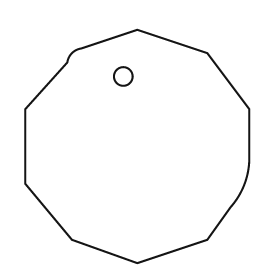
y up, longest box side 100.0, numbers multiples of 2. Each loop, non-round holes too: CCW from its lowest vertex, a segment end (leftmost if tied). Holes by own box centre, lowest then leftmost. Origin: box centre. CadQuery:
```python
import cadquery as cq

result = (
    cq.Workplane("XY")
    .moveTo(0.0, -50.0)
    .lineTo(30.0, -40.0)
    .lineTo(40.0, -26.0)
    .threePointArc((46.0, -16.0), (48.0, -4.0))
    .lineTo(48.0, 16.0)
    .lineTo(30.0, 40.0)
    .lineTo(0.0, 50.0)
    .lineTo(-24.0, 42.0)
    .threePointArc((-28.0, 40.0), (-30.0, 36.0))
    .lineTo(-48.0, 16.0)
    .lineTo(-48.0, -16.0)
    .lineTo(-28.0, -40.0)
    .close()
    .moveTo(-6.0, 30.0)
    .circle(4.0)
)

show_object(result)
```